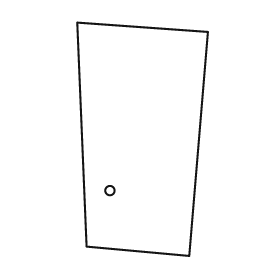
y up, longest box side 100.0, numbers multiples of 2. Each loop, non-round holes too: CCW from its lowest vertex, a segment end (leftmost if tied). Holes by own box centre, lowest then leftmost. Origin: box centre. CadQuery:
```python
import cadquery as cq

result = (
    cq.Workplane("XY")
    .moveTo(20.0, -50.0)
    .lineTo(28.0, 46.0)
    .lineTo(-28.0, 50.0)
    .lineTo(-24.0, -46.0)
    .close()
    .moveTo(-14.0, -22.0)
    .circle(2.0)
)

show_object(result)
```